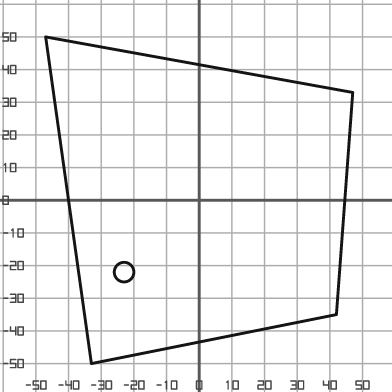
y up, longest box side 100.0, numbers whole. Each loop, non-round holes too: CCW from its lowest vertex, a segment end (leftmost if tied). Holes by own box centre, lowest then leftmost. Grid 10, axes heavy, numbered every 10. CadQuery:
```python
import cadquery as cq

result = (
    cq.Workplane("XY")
    .moveTo(-33.0, -50.0)
    .lineTo(42.0, -35.0)
    .lineTo(47.0, 33.0)
    .lineTo(-47.0, 50.0)
    .close()
    .moveTo(-23.0, -22.0)
    .circle(3.0)
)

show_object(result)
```